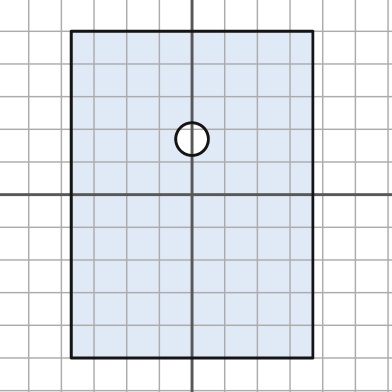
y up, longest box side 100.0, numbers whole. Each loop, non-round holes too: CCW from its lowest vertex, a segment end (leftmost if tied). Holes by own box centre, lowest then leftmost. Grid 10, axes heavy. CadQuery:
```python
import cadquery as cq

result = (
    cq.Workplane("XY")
    .moveTo(-37.0, -50.0)
    .lineTo(37.0, -50.0)
    .lineTo(37.0, 50.0)
    .lineTo(-37.0, 50.0)
    .close()
    .moveTo(0.0, 17.0)
    .circle(5.0)
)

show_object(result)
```